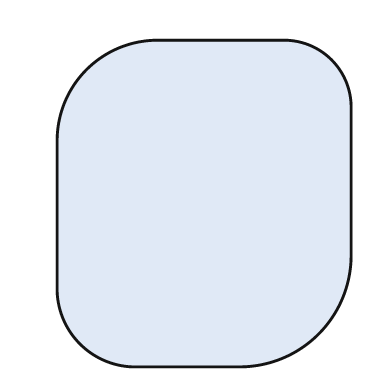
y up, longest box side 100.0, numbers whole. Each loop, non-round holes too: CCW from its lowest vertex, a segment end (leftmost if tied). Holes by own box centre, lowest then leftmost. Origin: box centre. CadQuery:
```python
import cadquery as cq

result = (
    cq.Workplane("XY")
    .moveTo(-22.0, -50.0)
    .lineTo(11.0, -50.0)
    .threePointArc((35.0, -40.0), (45.0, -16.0))
    .lineTo(45.0, 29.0)
    .threePointArc((39.0, 44.0), (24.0, 50.0))
    .lineTo(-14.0, 50.0)
    .threePointArc((-36.0, 41.0), (-45.0, 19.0))
    .lineTo(-45.0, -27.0)
    .threePointArc((-38.0, -43.0), (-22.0, -50.0))
    .close()
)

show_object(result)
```